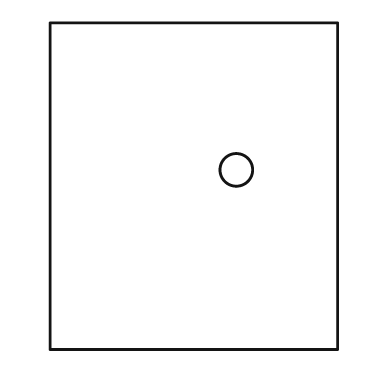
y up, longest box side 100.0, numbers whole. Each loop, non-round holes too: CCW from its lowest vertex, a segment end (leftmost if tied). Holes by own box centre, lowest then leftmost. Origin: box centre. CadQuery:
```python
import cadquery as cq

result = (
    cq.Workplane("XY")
    .moveTo(-44.0, -50.0)
    .lineTo(44.0, -50.0)
    .lineTo(44.0, 50.0)
    .lineTo(-44.0, 50.0)
    .close()
    .moveTo(13.0, 5.0)
    .circle(5.0)
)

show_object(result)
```